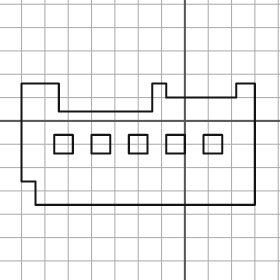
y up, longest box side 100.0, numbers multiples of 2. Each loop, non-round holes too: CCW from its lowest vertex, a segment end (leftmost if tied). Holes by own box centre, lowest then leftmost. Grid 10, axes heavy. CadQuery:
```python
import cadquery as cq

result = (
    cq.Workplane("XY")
    .moveTo(-64.0, -36.0)
    .lineTo(30.0, -36.0)
    .lineTo(30.0, 16.0)
    .lineTo(22.0, 16.0)
    .lineTo(22.0, 10.0)
    .lineTo(-8.0, 10.0)
    .lineTo(-8.0, 16.0)
    .lineTo(-14.0, 16.0)
    .lineTo(-14.0, 4.0)
    .lineTo(-54.0, 4.0)
    .lineTo(-54.0, 16.0)
    .lineTo(-70.0, 16.0)
    .lineTo(-70.0, -26.0)
    .lineTo(-64.0, -26.0)
    .close()
    .moveTo(-56.0, -14.0)
    .lineTo(-48.0, -14.0)
    .lineTo(-48.0, -6.0)
    .lineTo(-56.0, -6.0)
    .close()
    .moveTo(-40.0, -14.0)
    .lineTo(-32.0, -14.0)
    .lineTo(-32.0, -6.0)
    .lineTo(-40.0, -6.0)
    .close()
    .moveTo(-24.0, -14.0)
    .lineTo(-16.0, -14.0)
    .lineTo(-16.0, -6.0)
    .lineTo(-24.0, -6.0)
    .close()
    .moveTo(-8.0, -14.0)
    .lineTo(0.0, -14.0)
    .lineTo(0.0, -6.0)
    .lineTo(-8.0, -6.0)
    .close()
    .moveTo(8.0, -14.0)
    .lineTo(16.0, -14.0)
    .lineTo(16.0, -6.0)
    .lineTo(8.0, -6.0)
    .close()
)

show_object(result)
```